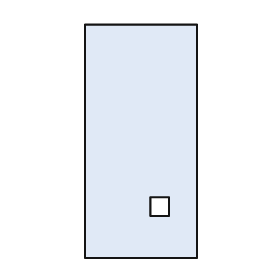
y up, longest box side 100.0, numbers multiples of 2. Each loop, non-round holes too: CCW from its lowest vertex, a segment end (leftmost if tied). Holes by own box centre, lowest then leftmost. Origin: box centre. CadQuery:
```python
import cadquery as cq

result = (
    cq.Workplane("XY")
    .moveTo(-24.0, -50.0)
    .lineTo(24.0, -50.0)
    .lineTo(24.0, 50.0)
    .lineTo(-24.0, 50.0)
    .close()
    .moveTo(4.0, -32.0)
    .lineTo(12.0, -32.0)
    .lineTo(12.0, -24.0)
    .lineTo(4.0, -24.0)
    .close()
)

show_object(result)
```